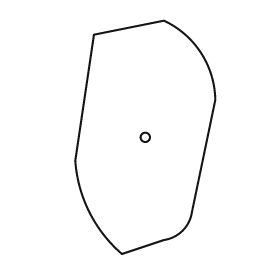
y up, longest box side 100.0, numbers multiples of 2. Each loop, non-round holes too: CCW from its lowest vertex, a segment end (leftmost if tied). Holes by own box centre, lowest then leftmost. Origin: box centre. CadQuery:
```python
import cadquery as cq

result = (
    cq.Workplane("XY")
    .moveTo(-10.0, -50.0)
    .lineTo(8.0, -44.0)
    .threePointArc((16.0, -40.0), (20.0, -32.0))
    .lineTo(30.0, 16.0)
    .threePointArc((24.0, 36.0), (8.0, 50.0))
    .lineTo(-22.0, 44.0)
    .lineTo(-30.0, -10.0)
    .threePointArc((-24.0, -32.0), (-10.0, -50.0))
    .close()
    .moveTo(0.0, 0.0)
    .circle(2.0)
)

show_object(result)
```